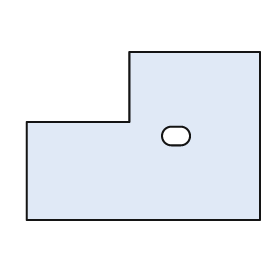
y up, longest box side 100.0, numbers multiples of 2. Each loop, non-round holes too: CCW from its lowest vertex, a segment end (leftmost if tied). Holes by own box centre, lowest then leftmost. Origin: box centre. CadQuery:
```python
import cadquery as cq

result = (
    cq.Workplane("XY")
    .moveTo(-50.0, -36.0)
    .lineTo(50.0, -36.0)
    .lineTo(50.0, 36.0)
    .lineTo(-6.0, 36.0)
    .lineTo(-6.0, 6.0)
    .lineTo(-50.0, 6.0)
    .close()
    .moveTo(12.0, -4.0)
    .lineTo(16.0, -4.0)
    .threePointArc((20.0, 0.0), (16.0, 4.0))
    .lineTo(12.0, 4.0)
    .threePointArc((8.0, 0.0), (12.0, -4.0))
    .close()
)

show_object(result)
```